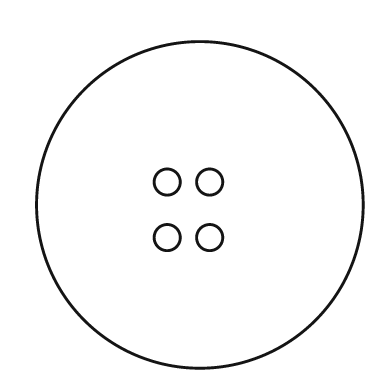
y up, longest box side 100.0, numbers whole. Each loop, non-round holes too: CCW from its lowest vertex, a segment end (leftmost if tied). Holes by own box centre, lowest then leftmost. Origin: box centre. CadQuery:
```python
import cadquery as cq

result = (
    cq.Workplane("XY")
    .moveTo(0.0, 0.0)
    .circle(50.0)
    .moveTo(-10.0, -10.0)
    .circle(4.0)
    .moveTo(3.0, -10.0)
    .circle(4.0)
    .moveTo(-10.0, 7.0)
    .circle(4.0)
    .moveTo(3.0, 7.0)
    .circle(4.0)
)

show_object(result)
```